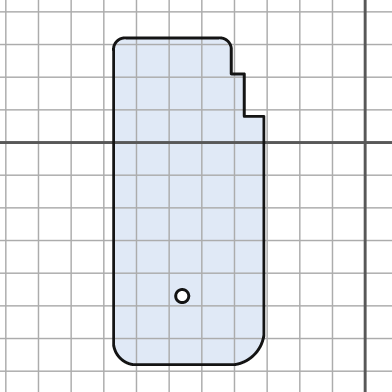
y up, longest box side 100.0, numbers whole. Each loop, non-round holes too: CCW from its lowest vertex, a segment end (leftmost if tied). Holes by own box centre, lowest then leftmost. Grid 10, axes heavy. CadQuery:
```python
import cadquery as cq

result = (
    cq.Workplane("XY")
    .moveTo(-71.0, -68.0)
    .lineTo(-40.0, -68.0)
    .threePointArc((-34.0, -65.0), (-31.0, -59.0))
    .lineTo(-31.0, 8.0)
    .lineTo(-37.0, 8.0)
    .lineTo(-37.0, 21.0)
    .lineTo(-41.0, 21.0)
    .lineTo(-41.0, 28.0)
    .threePointArc((-42.0, 31.0), (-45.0, 32.0))
    .lineTo(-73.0, 32.0)
    .threePointArc((-76.0, 31.0), (-77.0, 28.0))
    .lineTo(-77.0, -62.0)
    .threePointArc((-75.0, -66.0), (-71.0, -68.0))
    .close()
    .moveTo(-56.0, -47.0)
    .circle(2.0)
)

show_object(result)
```